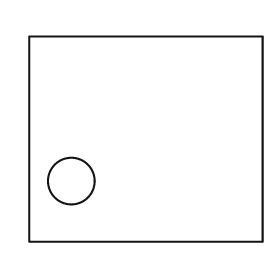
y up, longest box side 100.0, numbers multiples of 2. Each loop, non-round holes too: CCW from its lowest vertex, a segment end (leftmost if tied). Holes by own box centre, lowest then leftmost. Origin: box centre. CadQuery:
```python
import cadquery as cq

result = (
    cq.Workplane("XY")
    .moveTo(-50.0, -44.0)
    .lineTo(50.0, -44.0)
    .lineTo(50.0, 44.0)
    .lineTo(-50.0, 44.0)
    .close()
    .moveTo(-32.0, -18.0)
    .circle(10.0)
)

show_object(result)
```